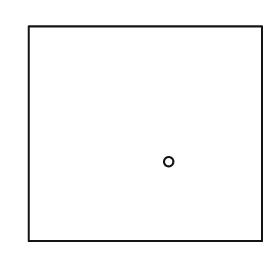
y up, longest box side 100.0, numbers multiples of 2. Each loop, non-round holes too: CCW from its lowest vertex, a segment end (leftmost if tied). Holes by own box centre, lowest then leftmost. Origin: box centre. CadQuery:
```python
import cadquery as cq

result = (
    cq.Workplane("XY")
    .moveTo(-50.0, -46.0)
    .lineTo(50.0, -46.0)
    .lineTo(50.0, 46.0)
    .lineTo(-50.0, 46.0)
    .close()
    .moveTo(10.0, -12.0)
    .circle(2.0)
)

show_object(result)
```